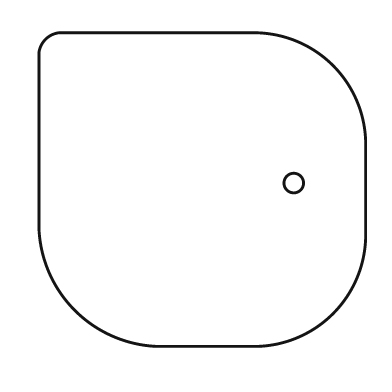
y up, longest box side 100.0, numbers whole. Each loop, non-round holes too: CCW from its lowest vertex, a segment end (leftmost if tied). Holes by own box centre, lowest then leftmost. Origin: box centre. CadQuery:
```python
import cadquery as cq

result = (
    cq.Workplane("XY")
    .moveTo(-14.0, -48.0)
    .lineTo(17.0, -48.0)
    .threePointArc((40.0, -38.0), (50.0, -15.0))
    .lineTo(50.0, 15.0)
    .threePointArc((40.0, 38.0), (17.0, 48.0))
    .lineTo(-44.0, 48.0)
    .threePointArc((-48.0, 46.0), (-50.0, 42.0))
    .lineTo(-50.0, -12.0)
    .threePointArc((-39.0, -37.0), (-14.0, -48.0))
    .close()
    .moveTo(28.0, 2.0)
    .circle(3.0)
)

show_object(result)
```